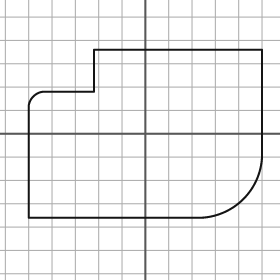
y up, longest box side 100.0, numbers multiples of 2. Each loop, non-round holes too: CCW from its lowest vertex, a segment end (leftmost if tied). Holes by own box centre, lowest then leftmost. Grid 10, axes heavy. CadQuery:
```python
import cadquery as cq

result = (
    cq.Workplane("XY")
    .moveTo(-50.0, -36.0)
    .lineTo(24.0, -36.0)
    .threePointArc((42.0, -28.0), (50.0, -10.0))
    .lineTo(50.0, 36.0)
    .lineTo(-22.0, 36.0)
    .lineTo(-22.0, 18.0)
    .lineTo(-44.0, 18.0)
    .threePointArc((-48.0, 16.0), (-50.0, 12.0))
    .close()
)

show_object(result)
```